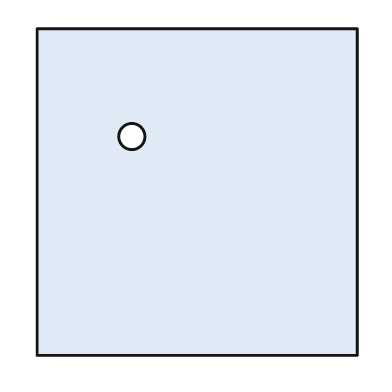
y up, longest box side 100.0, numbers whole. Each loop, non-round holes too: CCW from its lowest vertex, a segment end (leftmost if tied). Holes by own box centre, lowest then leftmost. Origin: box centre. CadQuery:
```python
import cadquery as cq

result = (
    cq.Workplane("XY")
    .moveTo(-49.0, -50.0)
    .lineTo(49.0, -50.0)
    .lineTo(49.0, 50.0)
    .lineTo(-49.0, 50.0)
    .close()
    .moveTo(-20.0, 17.0)
    .circle(4.0)
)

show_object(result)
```